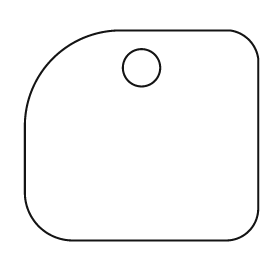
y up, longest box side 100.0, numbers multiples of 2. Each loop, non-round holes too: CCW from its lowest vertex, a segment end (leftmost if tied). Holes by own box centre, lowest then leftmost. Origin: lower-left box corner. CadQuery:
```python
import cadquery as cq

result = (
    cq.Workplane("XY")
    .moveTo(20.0, 0.0)
    .lineTo(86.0, 0.0)
    .threePointArc((96.0, 4.0), (100.0, 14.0))
    .lineTo(100.0, 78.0)
    .threePointArc((96.0, 86.0), (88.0, 90.0))
    .lineTo(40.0, 90.0)
    .threePointArc((12.0, 78.0), (0.0, 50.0))
    .lineTo(0.0, 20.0)
    .threePointArc((6.0, 6.0), (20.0, 0.0))
    .close()
    .moveTo(50.0, 74.0)
    .circle(8.0)
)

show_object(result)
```